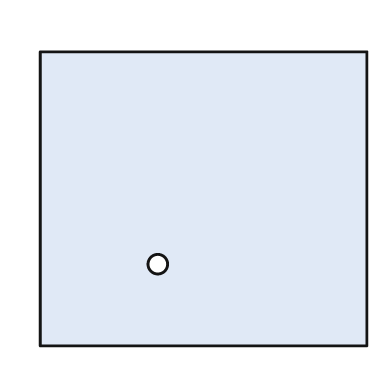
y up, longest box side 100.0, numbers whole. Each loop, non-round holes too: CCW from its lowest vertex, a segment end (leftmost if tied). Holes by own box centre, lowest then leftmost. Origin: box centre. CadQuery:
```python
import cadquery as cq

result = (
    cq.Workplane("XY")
    .moveTo(-50.0, -45.0)
    .lineTo(50.0, -45.0)
    .lineTo(50.0, 45.0)
    .lineTo(-50.0, 45.0)
    .close()
    .moveTo(-14.0, -20.0)
    .circle(3.0)
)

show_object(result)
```